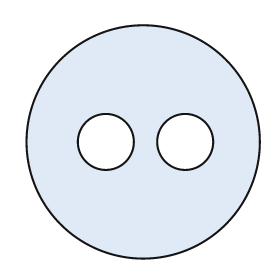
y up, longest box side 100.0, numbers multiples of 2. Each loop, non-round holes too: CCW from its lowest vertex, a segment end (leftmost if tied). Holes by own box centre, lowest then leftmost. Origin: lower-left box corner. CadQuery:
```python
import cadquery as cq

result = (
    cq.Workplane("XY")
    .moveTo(50.0, 50.0)
    .circle(50.0)
    .moveTo(34.0, 50.0)
    .circle(12.0)
    .moveTo(68.0, 50.0)
    .circle(12.0)
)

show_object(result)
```